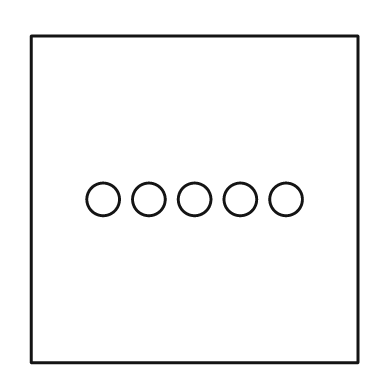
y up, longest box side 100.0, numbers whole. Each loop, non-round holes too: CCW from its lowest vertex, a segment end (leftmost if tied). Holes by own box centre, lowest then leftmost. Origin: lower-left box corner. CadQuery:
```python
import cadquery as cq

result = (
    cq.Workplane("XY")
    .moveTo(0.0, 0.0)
    .lineTo(100.0, 0.0)
    .lineTo(100.0, 100.0)
    .lineTo(0.0, 100.0)
    .close()
    .moveTo(22.0, 50.0)
    .circle(5.0)
    .moveTo(36.0, 50.0)
    .circle(5.0)
    .moveTo(50.0, 50.0)
    .circle(5.0)
    .moveTo(64.0, 50.0)
    .circle(5.0)
    .moveTo(78.0, 50.0)
    .circle(5.0)
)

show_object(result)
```